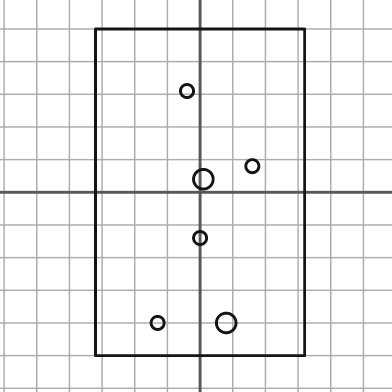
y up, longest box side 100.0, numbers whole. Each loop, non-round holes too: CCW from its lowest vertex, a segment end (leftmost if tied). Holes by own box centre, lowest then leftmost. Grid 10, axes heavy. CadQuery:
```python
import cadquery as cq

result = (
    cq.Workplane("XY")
    .moveTo(-32.0, -50.0)
    .lineTo(32.0, -50.0)
    .lineTo(32.0, 50.0)
    .lineTo(-32.0, 50.0)
    .close()
    .moveTo(-13.0, -40.0)
    .circle(2.0)
    .moveTo(8.0, -40.0)
    .circle(3.0)
    .moveTo(0.0, -14.0)
    .circle(2.0)
    .moveTo(1.0, 4.0)
    .circle(3.0)
    .moveTo(16.0, 8.0)
    .circle(2.0)
    .moveTo(-4.0, 31.0)
    .circle(2.0)
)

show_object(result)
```